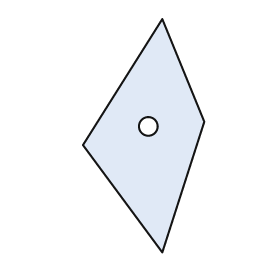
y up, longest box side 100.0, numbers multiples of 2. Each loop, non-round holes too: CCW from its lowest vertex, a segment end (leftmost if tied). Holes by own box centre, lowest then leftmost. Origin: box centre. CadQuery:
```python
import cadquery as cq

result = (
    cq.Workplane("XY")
    .moveTo(8.0, -50.0)
    .lineTo(26.0, 6.0)
    .lineTo(8.0, 50.0)
    .lineTo(-26.0, -4.0)
    .close()
    .moveTo(2.0, 4.0)
    .circle(4.0)
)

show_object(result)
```